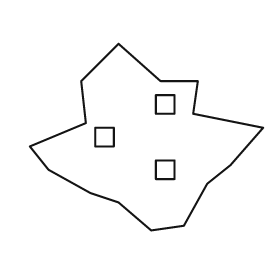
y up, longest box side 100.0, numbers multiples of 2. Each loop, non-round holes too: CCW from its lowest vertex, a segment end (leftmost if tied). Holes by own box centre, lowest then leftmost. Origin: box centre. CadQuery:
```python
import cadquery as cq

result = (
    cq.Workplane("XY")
    .moveTo(2.0, -40.0)
    .lineTo(16.0, -38.0)
    .lineTo(26.0, -20.0)
    .lineTo(36.0, -12.0)
    .lineTo(50.0, 4.0)
    .lineTo(20.0, 10.0)
    .lineTo(22.0, 24.0)
    .lineTo(6.0, 24.0)
    .lineTo(-12.0, 40.0)
    .lineTo(-28.0, 24.0)
    .lineTo(-26.0, 6.0)
    .lineTo(-50.0, -4.0)
    .lineTo(-42.0, -14.0)
    .lineTo(-24.0, -24.0)
    .lineTo(-12.0, -28.0)
    .close()
    .moveTo(4.0, -18.0)
    .lineTo(12.0, -18.0)
    .lineTo(12.0, -10.0)
    .lineTo(4.0, -10.0)
    .close()
    .moveTo(-22.0, -4.0)
    .lineTo(-14.0, -4.0)
    .lineTo(-14.0, 4.0)
    .lineTo(-22.0, 4.0)
    .close()
    .moveTo(4.0, 10.0)
    .lineTo(12.0, 10.0)
    .lineTo(12.0, 18.0)
    .lineTo(4.0, 18.0)
    .close()
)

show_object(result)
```